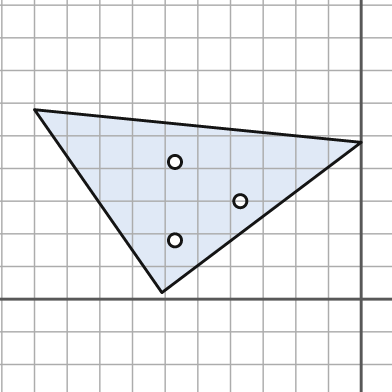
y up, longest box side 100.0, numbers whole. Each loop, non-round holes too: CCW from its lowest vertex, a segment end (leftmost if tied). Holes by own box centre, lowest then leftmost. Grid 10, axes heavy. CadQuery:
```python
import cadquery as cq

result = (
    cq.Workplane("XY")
    .moveTo(-61.0, 2.0)
    .lineTo(0.0, 48.0)
    .lineTo(-100.0, 58.0)
    .close()
    .moveTo(-57.0, 18.0)
    .circle(2.0)
    .moveTo(-37.0, 30.0)
    .circle(2.0)
    .moveTo(-57.0, 42.0)
    .circle(2.0)
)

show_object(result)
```